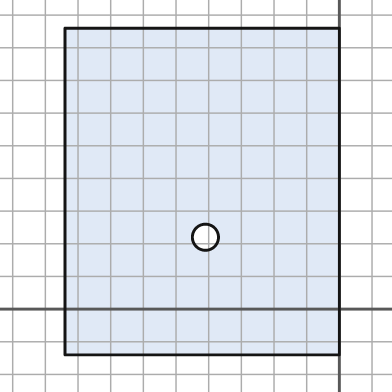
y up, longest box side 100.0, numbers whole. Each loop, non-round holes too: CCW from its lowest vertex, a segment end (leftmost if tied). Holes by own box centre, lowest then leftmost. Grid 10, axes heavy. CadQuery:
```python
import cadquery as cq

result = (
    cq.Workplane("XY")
    .moveTo(-84.0, -14.0)
    .lineTo(0.0, -14.0)
    .lineTo(0.0, 86.0)
    .lineTo(-84.0, 86.0)
    .close()
    .moveTo(-41.0, 22.0)
    .circle(4.0)
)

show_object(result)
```